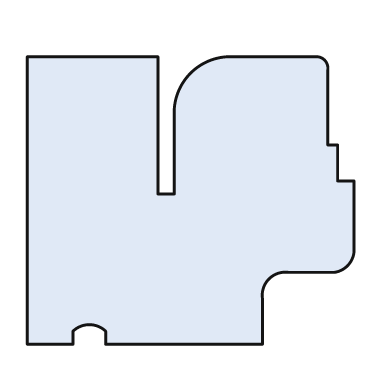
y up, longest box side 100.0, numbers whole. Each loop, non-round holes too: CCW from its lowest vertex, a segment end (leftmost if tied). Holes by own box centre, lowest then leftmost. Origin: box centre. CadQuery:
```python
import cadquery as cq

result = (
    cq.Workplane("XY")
    .moveTo(-50.0, -44.0)
    .lineTo(-36.0, -44.0)
    .lineTo(-36.0, -40.0)
    .threePointArc((-31.0, -38.0), (-26.0, -40.0))
    .lineTo(-26.0, -44.0)
    .lineTo(22.0, -44.0)
    .lineTo(22.0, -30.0)
    .threePointArc((24.0, -24.0), (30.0, -22.0))
    .lineTo(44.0, -22.0)
    .threePointArc((48.0, -20.0), (50.0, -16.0))
    .lineTo(50.0, 6.0)
    .lineTo(45.0, 6.0)
    .lineTo(45.0, 17.0)
    .lineTo(42.0, 17.0)
    .lineTo(42.0, 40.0)
    .threePointArc((41.0, 43.0), (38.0, 44.0))
    .lineTo(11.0, 44.0)
    .threePointArc((0.0, 39.0), (-5.0, 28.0))
    .lineTo(-5.0, 2.0)
    .lineTo(-10.0, 2.0)
    .lineTo(-10.0, 44.0)
    .lineTo(-50.0, 44.0)
    .close()
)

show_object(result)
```